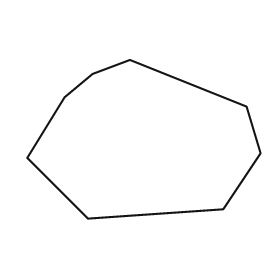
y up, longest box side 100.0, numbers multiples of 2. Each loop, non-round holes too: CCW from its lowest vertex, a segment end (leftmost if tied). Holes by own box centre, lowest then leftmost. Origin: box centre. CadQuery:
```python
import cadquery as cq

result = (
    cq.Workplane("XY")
    .moveTo(-24.0, -34.0)
    .lineTo(34.0, -30.0)
    .lineTo(50.0, -6.0)
    .lineTo(44.0, 14.0)
    .lineTo(-6.0, 34.0)
    .lineTo(-22.0, 28.0)
    .lineTo(-34.0, 18.0)
    .lineTo(-50.0, -8.0)
    .close()
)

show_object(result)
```